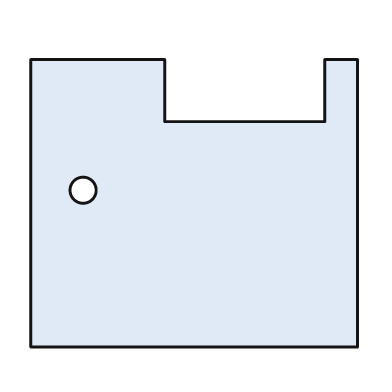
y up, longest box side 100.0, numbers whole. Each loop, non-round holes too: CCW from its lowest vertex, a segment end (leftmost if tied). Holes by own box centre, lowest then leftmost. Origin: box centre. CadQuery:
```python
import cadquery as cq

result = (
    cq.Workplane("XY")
    .moveTo(-50.0, -44.0)
    .lineTo(50.0, -44.0)
    .lineTo(50.0, 44.0)
    .lineTo(40.0, 44.0)
    .lineTo(40.0, 25.0)
    .lineTo(-9.0, 25.0)
    .lineTo(-9.0, 44.0)
    .lineTo(-50.0, 44.0)
    .close()
    .moveTo(-34.0, 4.0)
    .circle(4.0)
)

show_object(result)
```